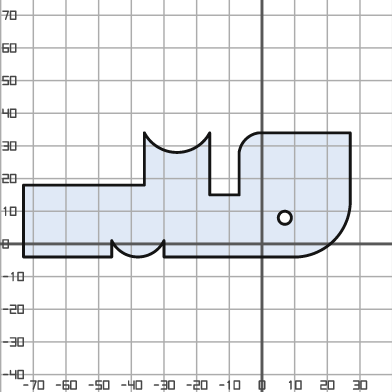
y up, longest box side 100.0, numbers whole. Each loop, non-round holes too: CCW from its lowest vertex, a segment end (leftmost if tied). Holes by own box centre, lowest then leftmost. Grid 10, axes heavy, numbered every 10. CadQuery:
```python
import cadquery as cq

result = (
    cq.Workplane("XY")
    .moveTo(-73.0, -4.0)
    .lineTo(-46.0, -4.0)
    .lineTo(-46.0, 1.0)
    .threePointArc((-38.0, -4.0), (-30.0, 1.0))
    .lineTo(-30.0, -4.0)
    .lineTo(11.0, -4.0)
    .threePointArc((22.0, 1.0), (27.0, 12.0))
    .lineTo(27.0, 34.0)
    .lineTo(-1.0, 34.0)
    .threePointArc((-5.0, 32.0), (-7.0, 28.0))
    .lineTo(-7.0, 15.0)
    .lineTo(-16.0, 15.0)
    .lineTo(-16.0, 34.0)
    .threePointArc((-26.0, 28.0), (-36.0, 34.0))
    .lineTo(-36.0, 18.0)
    .lineTo(-73.0, 18.0)
    .close()
    .moveTo(7.0, 8.0)
    .circle(2.0)
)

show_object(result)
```